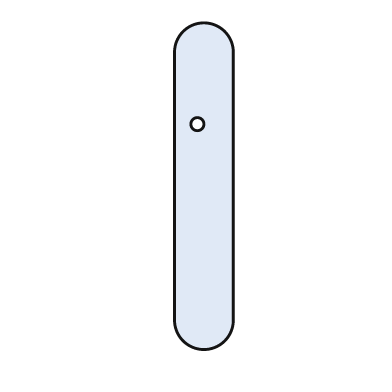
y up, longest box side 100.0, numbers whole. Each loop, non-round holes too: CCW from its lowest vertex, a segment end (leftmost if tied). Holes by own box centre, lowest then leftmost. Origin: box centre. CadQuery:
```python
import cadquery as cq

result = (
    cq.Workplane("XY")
    .moveTo(-9.0, -41.0)
    .threePointArc((0.0, -50.0), (9.0, -41.0))
    .lineTo(9.0, 41.0)
    .threePointArc((0.0, 50.0), (-9.0, 41.0))
    .close()
    .moveTo(-2.0, 19.0)
    .circle(2.0)
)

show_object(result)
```